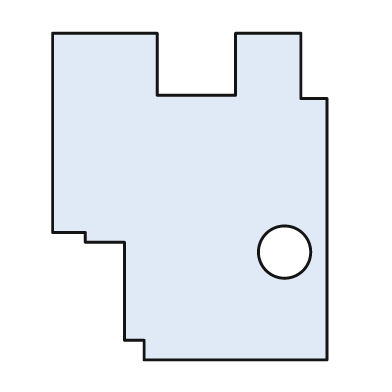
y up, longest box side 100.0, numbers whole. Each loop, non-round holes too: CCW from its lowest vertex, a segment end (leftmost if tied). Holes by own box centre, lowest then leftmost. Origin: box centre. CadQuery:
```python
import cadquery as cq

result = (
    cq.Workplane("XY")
    .moveTo(-14.0, -50.0)
    .lineTo(42.0, -50.0)
    .lineTo(42.0, 30.0)
    .lineTo(34.0, 30.0)
    .lineTo(34.0, 50.0)
    .lineTo(14.0, 50.0)
    .lineTo(14.0, 31.0)
    .lineTo(-10.0, 31.0)
    .lineTo(-10.0, 50.0)
    .lineTo(-42.0, 50.0)
    .lineTo(-42.0, -11.0)
    .lineTo(-32.0, -11.0)
    .lineTo(-32.0, -14.0)
    .lineTo(-20.0, -14.0)
    .lineTo(-20.0, -44.0)
    .lineTo(-14.0, -44.0)
    .close()
    .moveTo(29.0, -17.0)
    .circle(8.0)
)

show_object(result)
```